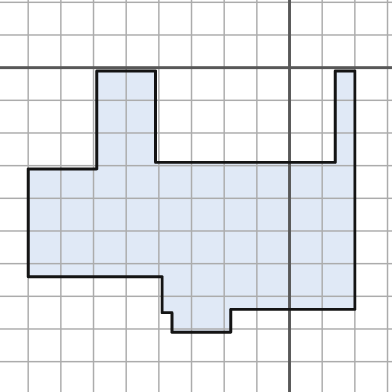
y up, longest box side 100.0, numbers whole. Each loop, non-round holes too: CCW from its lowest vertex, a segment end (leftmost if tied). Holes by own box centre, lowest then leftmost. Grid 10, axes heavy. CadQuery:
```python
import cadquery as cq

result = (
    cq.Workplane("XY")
    .moveTo(-36.0, -81.0)
    .lineTo(-18.0, -81.0)
    .lineTo(-18.0, -74.0)
    .lineTo(20.0, -74.0)
    .lineTo(20.0, -1.0)
    .lineTo(14.0, -1.0)
    .lineTo(14.0, -29.0)
    .lineTo(-41.0, -29.0)
    .lineTo(-41.0, -1.0)
    .lineTo(-59.0, -1.0)
    .lineTo(-59.0, -31.0)
    .lineTo(-80.0, -31.0)
    .lineTo(-80.0, -64.0)
    .lineTo(-39.0, -64.0)
    .lineTo(-39.0, -75.0)
    .lineTo(-36.0, -75.0)
    .close()
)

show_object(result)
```